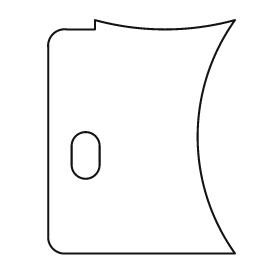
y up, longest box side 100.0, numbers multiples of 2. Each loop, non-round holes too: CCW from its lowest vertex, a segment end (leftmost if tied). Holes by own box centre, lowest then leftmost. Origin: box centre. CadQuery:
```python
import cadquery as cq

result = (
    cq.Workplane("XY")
    .moveTo(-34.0, -50.0)
    .lineTo(40.0, -50.0)
    .threePointArc((24.0, 0.0), (40.0, 50.0))
    .threePointArc((10.0, 46.0), (-20.0, 50.0))
    .lineTo(-20.0, 46.0)
    .lineTo(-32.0, 46.0)
    .threePointArc((-38.0, 44.0), (-40.0, 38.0))
    .lineTo(-40.0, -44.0)
    .threePointArc((-38.0, -48.0), (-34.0, -50.0))
    .close()
    .moveTo(-30.0, -12.0)
    .threePointArc((-24.0, -18.0), (-18.0, -12.0))
    .lineTo(-18.0, -4.0)
    .threePointArc((-24.0, 2.0), (-30.0, -4.0))
    .close()
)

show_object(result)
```